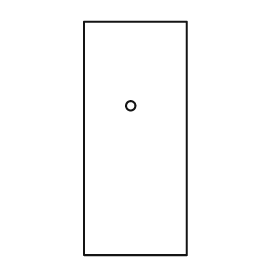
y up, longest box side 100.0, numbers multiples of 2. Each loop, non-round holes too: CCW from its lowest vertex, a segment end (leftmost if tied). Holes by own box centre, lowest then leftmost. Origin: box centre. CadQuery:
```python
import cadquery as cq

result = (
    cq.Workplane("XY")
    .moveTo(-22.0, -50.0)
    .lineTo(22.0, -50.0)
    .lineTo(22.0, 50.0)
    .lineTo(-22.0, 50.0)
    .close()
    .moveTo(-2.0, 14.0)
    .circle(2.0)
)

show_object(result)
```